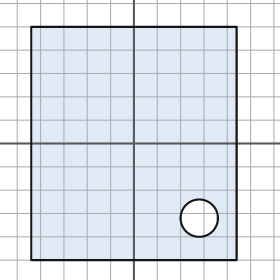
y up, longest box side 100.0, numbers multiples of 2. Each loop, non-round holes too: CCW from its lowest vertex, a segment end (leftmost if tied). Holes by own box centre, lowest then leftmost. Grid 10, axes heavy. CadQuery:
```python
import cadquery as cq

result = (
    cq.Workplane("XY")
    .moveTo(-44.0, -50.0)
    .lineTo(44.0, -50.0)
    .lineTo(44.0, 50.0)
    .lineTo(-44.0, 50.0)
    .close()
    .moveTo(28.0, -32.0)
    .circle(8.0)
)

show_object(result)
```